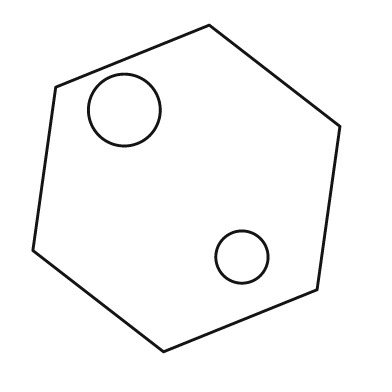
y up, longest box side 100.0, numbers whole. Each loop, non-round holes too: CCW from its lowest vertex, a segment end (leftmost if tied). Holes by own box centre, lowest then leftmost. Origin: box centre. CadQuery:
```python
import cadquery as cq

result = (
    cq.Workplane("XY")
    .moveTo(-7.0, -50.0)
    .lineTo(40.0, -31.0)
    .lineTo(47.0, 19.0)
    .lineTo(7.0, 50.0)
    .lineTo(-40.0, 31.0)
    .lineTo(-47.0, -19.0)
    .close()
    .moveTo(17.0, -21.0)
    .circle(8.0)
    .moveTo(-19.0, 24.0)
    .circle(11.0)
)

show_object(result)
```